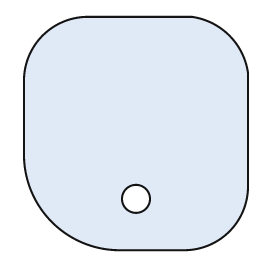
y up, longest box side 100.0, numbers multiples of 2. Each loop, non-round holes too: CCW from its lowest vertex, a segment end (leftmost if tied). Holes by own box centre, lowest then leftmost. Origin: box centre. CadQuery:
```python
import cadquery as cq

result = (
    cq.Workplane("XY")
    .moveTo(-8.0, -50.0)
    .lineTo(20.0, -50.0)
    .threePointArc((40.0, -42.0), (48.0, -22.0))
    .lineTo(48.0, 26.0)
    .threePointArc((40.0, 42.0), (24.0, 50.0))
    .lineTo(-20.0, 50.0)
    .threePointArc((-40.0, 42.0), (-48.0, 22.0))
    .lineTo(-48.0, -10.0)
    .threePointArc((-36.0, -38.0), (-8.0, -50.0))
    .close()
    .moveTo(0.0, -28.0)
    .circle(6.0)
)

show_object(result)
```